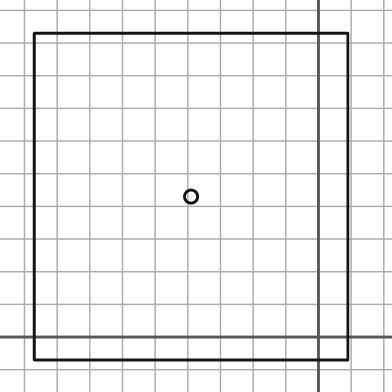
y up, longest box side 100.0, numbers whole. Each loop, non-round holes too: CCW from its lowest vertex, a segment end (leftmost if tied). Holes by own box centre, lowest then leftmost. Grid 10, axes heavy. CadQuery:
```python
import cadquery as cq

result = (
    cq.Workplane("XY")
    .moveTo(-87.0, -7.0)
    .lineTo(9.0, -7.0)
    .lineTo(9.0, 93.0)
    .lineTo(-87.0, 93.0)
    .close()
    .moveTo(-39.0, 43.0)
    .circle(2.0)
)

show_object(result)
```